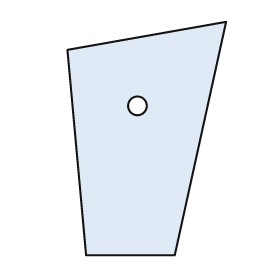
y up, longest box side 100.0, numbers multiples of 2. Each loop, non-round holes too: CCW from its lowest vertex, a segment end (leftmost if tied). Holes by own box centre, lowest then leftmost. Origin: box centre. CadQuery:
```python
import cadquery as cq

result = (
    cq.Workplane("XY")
    .moveTo(-26.0, -50.0)
    .lineTo(12.0, -50.0)
    .lineTo(34.0, 50.0)
    .lineTo(-34.0, 38.0)
    .close()
    .moveTo(-4.0, 14.0)
    .circle(4.0)
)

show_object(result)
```